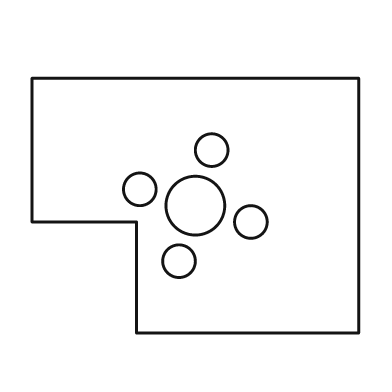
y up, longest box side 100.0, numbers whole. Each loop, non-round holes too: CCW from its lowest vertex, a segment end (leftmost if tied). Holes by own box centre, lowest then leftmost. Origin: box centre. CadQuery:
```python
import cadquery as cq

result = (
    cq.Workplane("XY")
    .moveTo(-18.0, -39.0)
    .lineTo(50.0, -39.0)
    .lineTo(50.0, 39.0)
    .lineTo(-50.0, 39.0)
    .lineTo(-50.0, -5.0)
    .lineTo(-18.0, -5.0)
    .close()
    .moveTo(-5.0, -17.0)
    .circle(5.0)
    .moveTo(17.0, -5.0)
    .circle(5.0)
    .moveTo(0.0, 0.0)
    .circle(9.0)
    .moveTo(-17.0, 5.0)
    .circle(5.0)
    .moveTo(5.0, 17.0)
    .circle(5.0)
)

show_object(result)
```